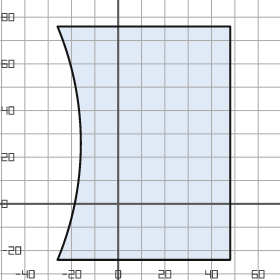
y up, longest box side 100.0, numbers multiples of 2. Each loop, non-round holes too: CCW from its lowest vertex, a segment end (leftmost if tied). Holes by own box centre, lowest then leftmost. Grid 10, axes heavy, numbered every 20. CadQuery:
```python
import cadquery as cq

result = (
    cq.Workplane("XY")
    .moveTo(-26.0, -24.0)
    .lineTo(48.0, -24.0)
    .lineTo(48.0, 76.0)
    .lineTo(-26.0, 76.0)
    .threePointArc((-16.0, 26.0), (-26.0, -24.0))
    .close()
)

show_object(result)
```